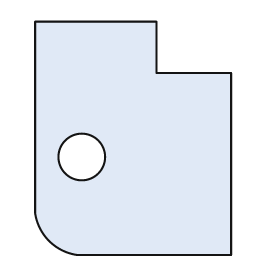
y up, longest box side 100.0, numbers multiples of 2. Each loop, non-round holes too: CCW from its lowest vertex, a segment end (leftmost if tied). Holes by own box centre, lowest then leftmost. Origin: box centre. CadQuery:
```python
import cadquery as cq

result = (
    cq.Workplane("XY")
    .moveTo(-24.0, -50.0)
    .lineTo(42.0, -50.0)
    .lineTo(42.0, 28.0)
    .lineTo(10.0, 28.0)
    .lineTo(10.0, 50.0)
    .lineTo(-42.0, 50.0)
    .lineTo(-42.0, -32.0)
    .threePointArc((-36.0, -44.0), (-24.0, -50.0))
    .close()
    .moveTo(-22.0, -8.0)
    .circle(10.0)
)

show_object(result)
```